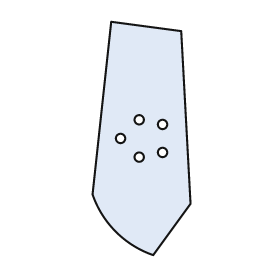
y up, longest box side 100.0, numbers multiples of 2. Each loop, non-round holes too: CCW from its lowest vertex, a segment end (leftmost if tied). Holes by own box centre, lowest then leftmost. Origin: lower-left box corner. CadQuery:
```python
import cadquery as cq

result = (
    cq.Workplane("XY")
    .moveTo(26.0, 0.0)
    .lineTo(42.0, 22.0)
    .lineTo(38.0, 96.0)
    .lineTo(8.0, 100.0)
    .lineTo(0.0, 26.0)
    .threePointArc((10.0, 10.0), (26.0, 0.0))
    .close()
    .moveTo(20.0, 42.0)
    .circle(2.0)
    .moveTo(30.0, 44.0)
    .circle(2.0)
    .moveTo(12.0, 50.0)
    .circle(2.0)
    .moveTo(30.0, 56.0)
    .circle(2.0)
    .moveTo(20.0, 58.0)
    .circle(2.0)
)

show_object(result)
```